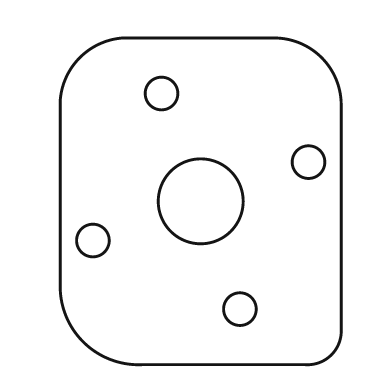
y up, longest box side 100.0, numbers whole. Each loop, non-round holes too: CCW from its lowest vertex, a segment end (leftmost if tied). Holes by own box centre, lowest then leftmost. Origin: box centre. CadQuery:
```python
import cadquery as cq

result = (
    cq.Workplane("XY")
    .moveTo(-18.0, -50.0)
    .lineTo(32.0, -50.0)
    .threePointArc((40.0, -47.0), (43.0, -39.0))
    .lineTo(43.0, 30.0)
    .threePointArc((37.0, 44.0), (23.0, 50.0))
    .lineTo(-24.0, 50.0)
    .threePointArc((-37.0, 44.0), (-43.0, 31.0))
    .lineTo(-43.0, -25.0)
    .threePointArc((-36.0, -43.0), (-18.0, -50.0))
    .close()
    .moveTo(12.0, -33.0)
    .circle(5.0)
    .moveTo(-33.0, -12.0)
    .circle(5.0)
    .moveTo(0.0, 0.0)
    .circle(13.0)
    .moveTo(33.0, 12.0)
    .circle(5.0)
    .moveTo(-12.0, 33.0)
    .circle(5.0)
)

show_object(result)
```